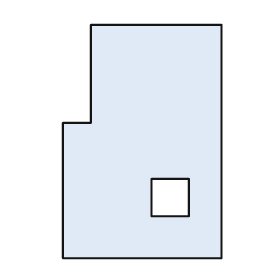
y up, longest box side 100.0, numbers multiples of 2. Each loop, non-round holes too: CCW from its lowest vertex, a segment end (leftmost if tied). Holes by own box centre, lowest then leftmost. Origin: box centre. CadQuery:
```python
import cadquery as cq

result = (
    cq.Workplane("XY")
    .moveTo(-34.0, -50.0)
    .lineTo(34.0, -50.0)
    .lineTo(34.0, 50.0)
    .lineTo(-22.0, 50.0)
    .lineTo(-22.0, 8.0)
    .lineTo(-34.0, 8.0)
    .close()
    .moveTo(4.0, -32.0)
    .lineTo(20.0, -32.0)
    .lineTo(20.0, -16.0)
    .lineTo(4.0, -16.0)
    .close()
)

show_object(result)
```